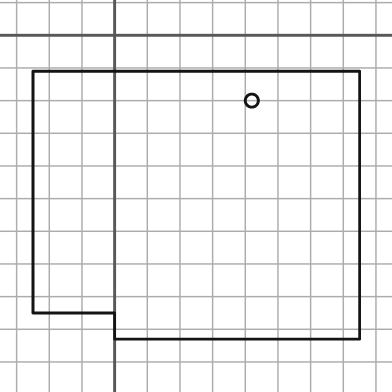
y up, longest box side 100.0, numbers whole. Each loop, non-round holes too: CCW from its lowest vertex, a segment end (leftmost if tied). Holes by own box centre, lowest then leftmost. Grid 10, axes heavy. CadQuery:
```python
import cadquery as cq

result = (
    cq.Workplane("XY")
    .moveTo(0.0, -93.0)
    .lineTo(75.0, -93.0)
    .lineTo(75.0, -11.0)
    .lineTo(-25.0, -11.0)
    .lineTo(-25.0, -85.0)
    .lineTo(0.0, -85.0)
    .close()
    .moveTo(42.0, -20.0)
    .circle(2.0)
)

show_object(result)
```